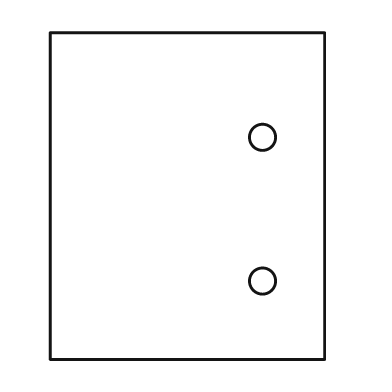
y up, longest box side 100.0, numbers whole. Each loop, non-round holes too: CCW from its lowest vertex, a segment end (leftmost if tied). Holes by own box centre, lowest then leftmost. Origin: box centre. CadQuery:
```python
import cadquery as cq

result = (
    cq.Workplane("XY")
    .moveTo(-42.0, -50.0)
    .lineTo(42.0, -50.0)
    .lineTo(42.0, 50.0)
    .lineTo(-42.0, 50.0)
    .close()
    .moveTo(23.0, -26.0)
    .circle(4.0)
    .moveTo(23.0, 18.0)
    .circle(4.0)
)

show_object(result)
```